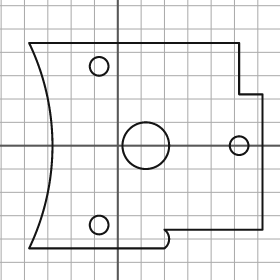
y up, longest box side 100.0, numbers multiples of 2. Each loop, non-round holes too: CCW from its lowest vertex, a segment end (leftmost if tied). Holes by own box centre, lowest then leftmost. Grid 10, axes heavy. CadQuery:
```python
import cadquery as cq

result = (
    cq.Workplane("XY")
    .moveTo(-38.0, -44.0)
    .lineTo(20.0, -44.0)
    .threePointArc((22.0, -40.0), (20.0, -36.0))
    .lineTo(62.0, -36.0)
    .lineTo(62.0, 22.0)
    .lineTo(52.0, 22.0)
    .lineTo(52.0, 44.0)
    .lineTo(-38.0, 44.0)
    .threePointArc((-28.0, 0.0), (-38.0, -44.0))
    .close()
    .moveTo(-8.0, -34.0)
    .circle(4.0)
    .moveTo(12.0, 0.0)
    .circle(10.0)
    .moveTo(52.0, 0.0)
    .circle(4.0)
    .moveTo(-8.0, 34.0)
    .circle(4.0)
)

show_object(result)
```